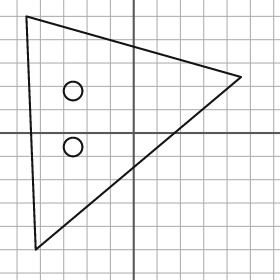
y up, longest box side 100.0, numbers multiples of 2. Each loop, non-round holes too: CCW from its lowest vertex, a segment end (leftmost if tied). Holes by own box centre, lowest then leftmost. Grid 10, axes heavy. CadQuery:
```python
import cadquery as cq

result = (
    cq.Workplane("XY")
    .moveTo(-42.0, -50.0)
    .lineTo(46.0, 24.0)
    .lineTo(-46.0, 50.0)
    .close()
    .moveTo(-26.0, -6.0)
    .circle(4.0)
    .moveTo(-26.0, 18.0)
    .circle(4.0)
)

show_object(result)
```